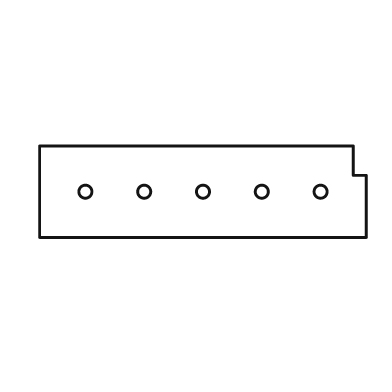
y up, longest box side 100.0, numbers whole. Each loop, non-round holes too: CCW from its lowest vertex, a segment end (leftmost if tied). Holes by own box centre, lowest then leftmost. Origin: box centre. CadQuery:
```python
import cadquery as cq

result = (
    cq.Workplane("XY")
    .moveTo(-50.0, -14.0)
    .lineTo(50.0, -14.0)
    .lineTo(50.0, 5.0)
    .lineTo(46.0, 5.0)
    .lineTo(46.0, 14.0)
    .lineTo(-50.0, 14.0)
    .close()
    .moveTo(-36.0, 0.0)
    .circle(2.0)
    .moveTo(-18.0, 0.0)
    .circle(2.0)
    .moveTo(0.0, 0.0)
    .circle(2.0)
    .moveTo(18.0, 0.0)
    .circle(2.0)
    .moveTo(36.0, 0.0)
    .circle(2.0)
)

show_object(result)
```